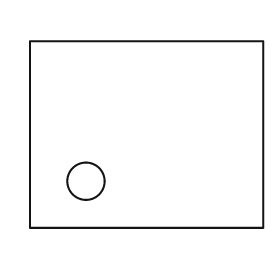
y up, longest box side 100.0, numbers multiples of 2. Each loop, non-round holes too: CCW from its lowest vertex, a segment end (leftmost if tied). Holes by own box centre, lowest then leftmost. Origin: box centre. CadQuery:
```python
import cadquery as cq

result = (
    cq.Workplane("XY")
    .moveTo(-50.0, -40.0)
    .lineTo(50.0, -40.0)
    .lineTo(50.0, 40.0)
    .lineTo(-50.0, 40.0)
    .close()
    .moveTo(-26.0, -20.0)
    .circle(8.0)
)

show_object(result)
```